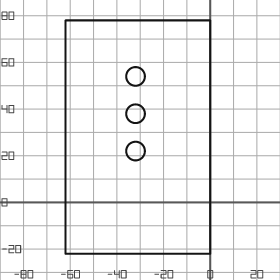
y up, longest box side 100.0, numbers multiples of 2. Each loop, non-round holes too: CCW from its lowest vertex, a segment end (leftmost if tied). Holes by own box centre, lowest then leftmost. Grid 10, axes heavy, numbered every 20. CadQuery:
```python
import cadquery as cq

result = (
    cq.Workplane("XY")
    .moveTo(-62.0, -22.0)
    .lineTo(0.0, -22.0)
    .lineTo(0.0, 78.0)
    .lineTo(-62.0, 78.0)
    .close()
    .moveTo(-32.0, 22.0)
    .circle(4.0)
    .moveTo(-32.0, 38.0)
    .circle(4.0)
    .moveTo(-32.0, 54.0)
    .circle(4.0)
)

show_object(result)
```